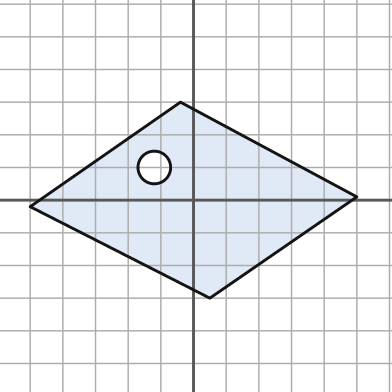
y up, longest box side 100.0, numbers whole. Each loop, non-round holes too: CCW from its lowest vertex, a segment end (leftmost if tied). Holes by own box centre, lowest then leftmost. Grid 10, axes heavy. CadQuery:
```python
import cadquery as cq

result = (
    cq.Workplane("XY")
    .moveTo(5.0, -30.0)
    .lineTo(50.0, 1.0)
    .lineTo(-4.0, 30.0)
    .lineTo(-50.0, -2.0)
    .close()
    .moveTo(-12.0, 10.0)
    .circle(5.0)
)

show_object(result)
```